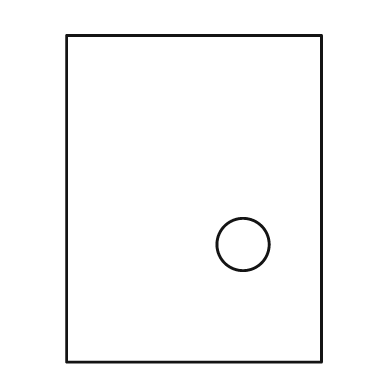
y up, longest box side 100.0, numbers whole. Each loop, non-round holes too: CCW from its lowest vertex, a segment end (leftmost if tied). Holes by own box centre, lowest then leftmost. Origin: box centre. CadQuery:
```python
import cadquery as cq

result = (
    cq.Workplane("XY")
    .moveTo(-39.0, -50.0)
    .lineTo(39.0, -50.0)
    .lineTo(39.0, 50.0)
    .lineTo(-39.0, 50.0)
    .close()
    .moveTo(15.0, -14.0)
    .circle(8.0)
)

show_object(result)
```